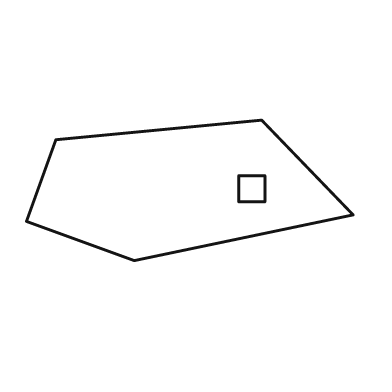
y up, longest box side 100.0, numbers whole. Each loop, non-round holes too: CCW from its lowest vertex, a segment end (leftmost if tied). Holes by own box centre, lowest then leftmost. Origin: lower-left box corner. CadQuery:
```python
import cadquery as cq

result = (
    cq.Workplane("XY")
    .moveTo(33.0, 0.0)
    .lineTo(100.0, 14.0)
    .lineTo(72.0, 43.0)
    .lineTo(9.0, 37.0)
    .lineTo(0.0, 12.0)
    .close()
    .moveTo(65.0, 18.0)
    .lineTo(73.0, 18.0)
    .lineTo(73.0, 26.0)
    .lineTo(65.0, 26.0)
    .close()
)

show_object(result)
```